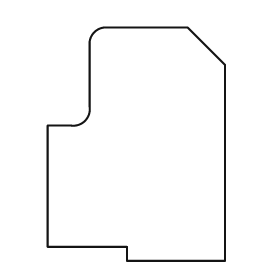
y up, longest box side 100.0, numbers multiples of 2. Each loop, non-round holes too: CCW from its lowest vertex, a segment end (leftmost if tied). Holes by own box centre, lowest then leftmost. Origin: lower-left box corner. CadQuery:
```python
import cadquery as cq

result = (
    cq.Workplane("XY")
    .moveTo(34.0, 0.0)
    .lineTo(76.0, 0.0)
    .lineTo(76.0, 84.0)
    .lineTo(60.0, 100.0)
    .lineTo(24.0, 100.0)
    .threePointArc((20.0, 98.0), (18.0, 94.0))
    .lineTo(18.0, 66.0)
    .threePointArc((16.0, 60.0), (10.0, 58.0))
    .lineTo(0.0, 58.0)
    .lineTo(0.0, 6.0)
    .lineTo(34.0, 6.0)
    .close()
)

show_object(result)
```